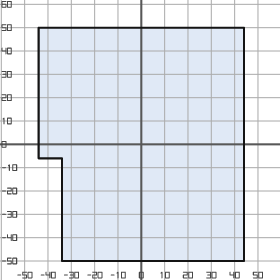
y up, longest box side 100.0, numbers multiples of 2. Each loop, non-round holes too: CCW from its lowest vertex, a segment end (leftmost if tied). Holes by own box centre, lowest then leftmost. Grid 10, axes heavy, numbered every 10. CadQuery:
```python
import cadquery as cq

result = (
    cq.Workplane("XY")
    .moveTo(-34.0, -50.0)
    .lineTo(44.0, -50.0)
    .lineTo(44.0, 50.0)
    .lineTo(-44.0, 50.0)
    .lineTo(-44.0, -6.0)
    .lineTo(-34.0, -6.0)
    .close()
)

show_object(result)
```